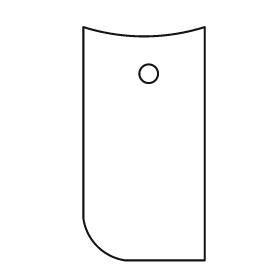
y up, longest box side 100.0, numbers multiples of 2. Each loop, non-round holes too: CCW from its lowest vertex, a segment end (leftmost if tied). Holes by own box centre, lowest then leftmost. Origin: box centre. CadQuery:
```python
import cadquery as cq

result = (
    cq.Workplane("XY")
    .moveTo(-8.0, -50.0)
    .lineTo(26.0, -50.0)
    .lineTo(26.0, 50.0)
    .threePointArc((0.0, 46.0), (-26.0, 50.0))
    .lineTo(-26.0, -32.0)
    .threePointArc((-20.0, -44.0), (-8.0, -50.0))
    .close()
    .moveTo(2.0, 30.0)
    .circle(4.0)
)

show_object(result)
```